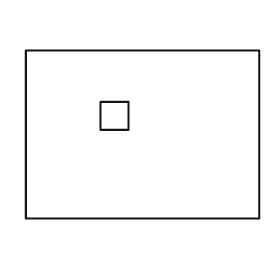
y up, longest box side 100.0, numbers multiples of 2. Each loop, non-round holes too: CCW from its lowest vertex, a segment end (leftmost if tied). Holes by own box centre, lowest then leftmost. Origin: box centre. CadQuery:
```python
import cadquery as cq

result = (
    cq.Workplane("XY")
    .moveTo(-50.0, -36.0)
    .lineTo(50.0, -36.0)
    .lineTo(50.0, 36.0)
    .lineTo(-50.0, 36.0)
    .close()
    .moveTo(-18.0, 2.0)
    .lineTo(-6.0, 2.0)
    .lineTo(-6.0, 14.0)
    .lineTo(-18.0, 14.0)
    .close()
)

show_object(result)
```